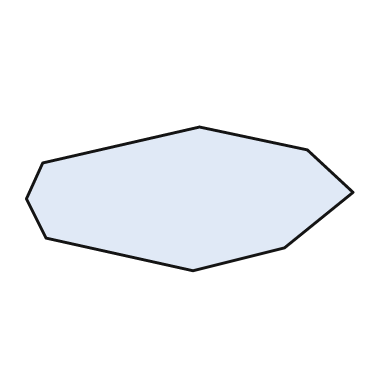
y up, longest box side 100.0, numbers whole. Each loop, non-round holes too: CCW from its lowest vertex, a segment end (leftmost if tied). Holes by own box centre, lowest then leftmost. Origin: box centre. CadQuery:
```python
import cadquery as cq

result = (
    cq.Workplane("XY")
    .moveTo(1.0, -22.0)
    .lineTo(29.0, -15.0)
    .lineTo(50.0, 2.0)
    .lineTo(36.0, 15.0)
    .lineTo(3.0, 22.0)
    .lineTo(-45.0, 11.0)
    .lineTo(-50.0, 0.0)
    .lineTo(-44.0, -12.0)
    .close()
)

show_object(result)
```